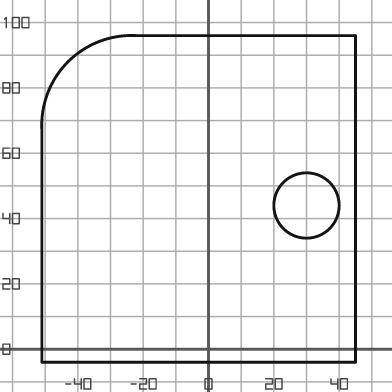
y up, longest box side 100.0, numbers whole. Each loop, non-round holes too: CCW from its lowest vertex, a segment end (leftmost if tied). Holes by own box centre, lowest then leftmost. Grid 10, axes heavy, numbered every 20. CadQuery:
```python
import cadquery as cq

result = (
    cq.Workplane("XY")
    .moveTo(-51.0, -4.0)
    .lineTo(45.0, -4.0)
    .lineTo(45.0, 96.0)
    .lineTo(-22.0, 96.0)
    .threePointArc((-43.0, 88.0), (-51.0, 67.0))
    .close()
    .moveTo(30.0, 44.0)
    .circle(10.0)
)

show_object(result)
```